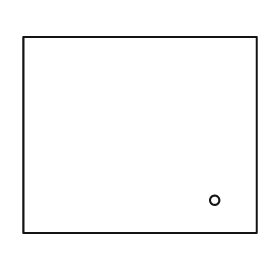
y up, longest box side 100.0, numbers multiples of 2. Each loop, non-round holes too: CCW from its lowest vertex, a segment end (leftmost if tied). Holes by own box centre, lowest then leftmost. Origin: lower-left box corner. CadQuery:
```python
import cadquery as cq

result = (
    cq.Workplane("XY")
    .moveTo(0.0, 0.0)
    .lineTo(100.0, 0.0)
    .lineTo(100.0, 84.0)
    .lineTo(0.0, 84.0)
    .close()
    .moveTo(82.0, 14.0)
    .circle(2.0)
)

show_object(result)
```